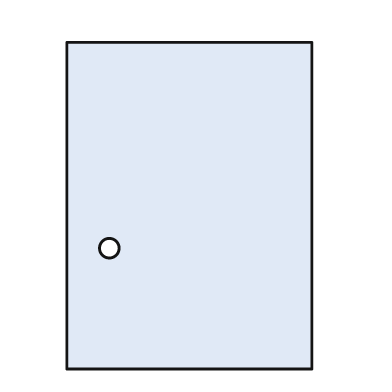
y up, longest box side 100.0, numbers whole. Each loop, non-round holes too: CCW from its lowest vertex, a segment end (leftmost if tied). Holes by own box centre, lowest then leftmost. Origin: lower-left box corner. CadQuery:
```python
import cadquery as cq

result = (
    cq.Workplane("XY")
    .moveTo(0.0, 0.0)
    .lineTo(75.0, 0.0)
    .lineTo(75.0, 100.0)
    .lineTo(0.0, 100.0)
    .close()
    .moveTo(13.0, 37.0)
    .circle(3.0)
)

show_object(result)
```